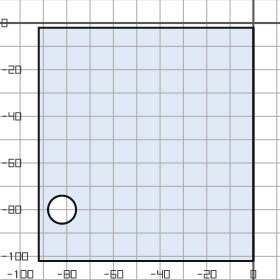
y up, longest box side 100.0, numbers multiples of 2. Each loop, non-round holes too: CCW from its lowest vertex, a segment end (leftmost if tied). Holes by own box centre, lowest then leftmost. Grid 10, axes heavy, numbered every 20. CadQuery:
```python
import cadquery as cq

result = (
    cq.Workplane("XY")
    .moveTo(-92.0, -102.0)
    .lineTo(0.0, -102.0)
    .lineTo(0.0, -2.0)
    .lineTo(-92.0, -2.0)
    .close()
    .moveTo(-82.0, -80.0)
    .circle(6.0)
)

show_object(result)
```